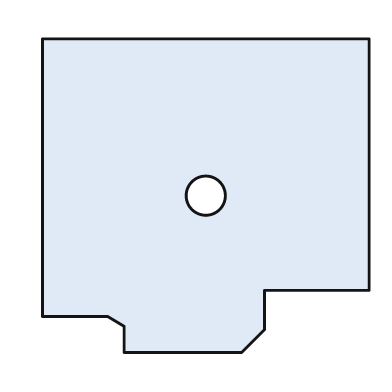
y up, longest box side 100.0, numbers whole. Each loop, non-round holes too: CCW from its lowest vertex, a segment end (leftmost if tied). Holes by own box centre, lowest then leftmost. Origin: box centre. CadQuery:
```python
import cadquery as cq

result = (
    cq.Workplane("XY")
    .moveTo(-25.0, -48.0)
    .lineTo(11.0, -48.0)
    .lineTo(18.0, -41.0)
    .lineTo(18.0, -29.0)
    .lineTo(50.0, -29.0)
    .lineTo(50.0, 48.0)
    .lineTo(-50.0, 48.0)
    .lineTo(-50.0, -37.0)
    .lineTo(-30.0, -37.0)
    .lineTo(-25.0, -40.0)
    .close()
    .moveTo(0.0, 0.0)
    .circle(6.0)
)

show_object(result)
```